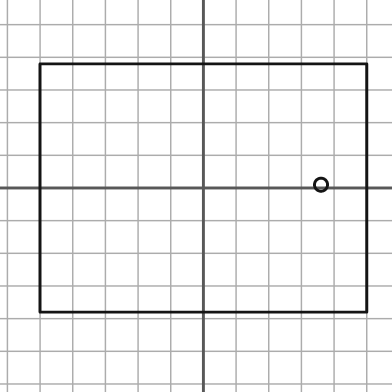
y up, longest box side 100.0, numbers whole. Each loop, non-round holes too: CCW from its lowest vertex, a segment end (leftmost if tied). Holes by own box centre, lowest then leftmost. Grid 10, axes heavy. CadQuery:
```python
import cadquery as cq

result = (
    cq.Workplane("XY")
    .moveTo(-50.0, -38.0)
    .lineTo(50.0, -38.0)
    .lineTo(50.0, 38.0)
    .lineTo(-50.0, 38.0)
    .close()
    .moveTo(36.0, 1.0)
    .circle(2.0)
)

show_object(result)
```